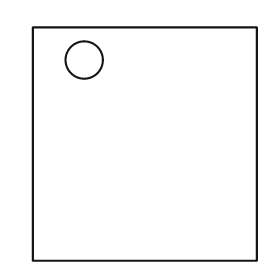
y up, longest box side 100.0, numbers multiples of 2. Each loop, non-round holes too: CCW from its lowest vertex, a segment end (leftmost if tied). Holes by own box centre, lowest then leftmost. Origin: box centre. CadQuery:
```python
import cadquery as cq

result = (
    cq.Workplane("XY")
    .moveTo(-48.0, -50.0)
    .lineTo(48.0, -50.0)
    .lineTo(48.0, 50.0)
    .lineTo(-48.0, 50.0)
    .close()
    .moveTo(-26.0, 36.0)
    .circle(8.0)
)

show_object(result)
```